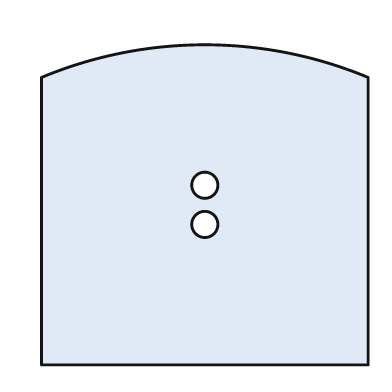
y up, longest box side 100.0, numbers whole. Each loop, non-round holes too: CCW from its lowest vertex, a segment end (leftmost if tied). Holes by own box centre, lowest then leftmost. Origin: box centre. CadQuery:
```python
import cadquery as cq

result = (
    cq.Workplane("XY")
    .moveTo(-50.0, -49.0)
    .lineTo(50.0, -49.0)
    .lineTo(50.0, 39.0)
    .threePointArc((0.0, 49.0), (-50.0, 39.0))
    .close()
    .moveTo(0.0, -6.0)
    .circle(4.0)
    .moveTo(0.0, 6.0)
    .circle(4.0)
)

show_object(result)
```